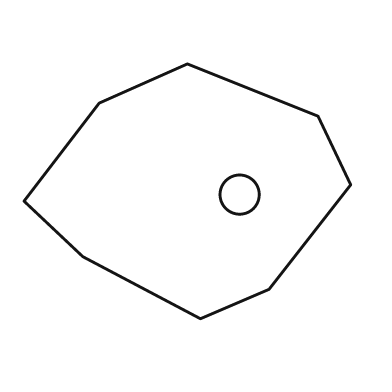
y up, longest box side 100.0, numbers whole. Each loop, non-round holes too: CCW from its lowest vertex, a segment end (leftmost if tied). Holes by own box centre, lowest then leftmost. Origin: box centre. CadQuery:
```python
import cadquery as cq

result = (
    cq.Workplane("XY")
    .moveTo(4.0, -39.0)
    .lineTo(25.0, -30.0)
    .lineTo(50.0, 2.0)
    .lineTo(40.0, 23.0)
    .lineTo(0.0, 39.0)
    .lineTo(-27.0, 27.0)
    .lineTo(-50.0, -3.0)
    .lineTo(-32.0, -20.0)
    .close()
    .moveTo(16.0, -1.0)
    .circle(6.0)
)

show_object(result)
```